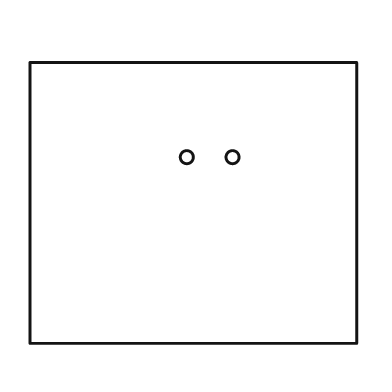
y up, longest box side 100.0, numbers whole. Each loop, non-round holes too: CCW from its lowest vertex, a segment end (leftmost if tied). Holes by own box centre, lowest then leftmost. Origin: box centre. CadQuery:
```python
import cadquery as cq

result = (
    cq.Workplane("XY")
    .moveTo(-50.0, -43.0)
    .lineTo(50.0, -43.0)
    .lineTo(50.0, 43.0)
    .lineTo(-50.0, 43.0)
    .close()
    .moveTo(-2.0, 14.0)
    .circle(2.0)
    .moveTo(12.0, 14.0)
    .circle(2.0)
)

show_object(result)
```